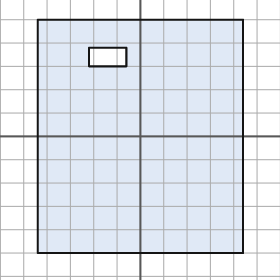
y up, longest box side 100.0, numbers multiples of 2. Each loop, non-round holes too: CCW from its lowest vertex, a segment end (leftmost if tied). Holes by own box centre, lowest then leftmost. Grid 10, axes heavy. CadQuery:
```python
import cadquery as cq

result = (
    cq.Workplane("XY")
    .moveTo(-44.0, -50.0)
    .lineTo(44.0, -50.0)
    .lineTo(44.0, 50.0)
    .lineTo(-44.0, 50.0)
    .close()
    .moveTo(-22.0, 30.0)
    .lineTo(-6.0, 30.0)
    .lineTo(-6.0, 38.0)
    .lineTo(-22.0, 38.0)
    .close()
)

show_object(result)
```